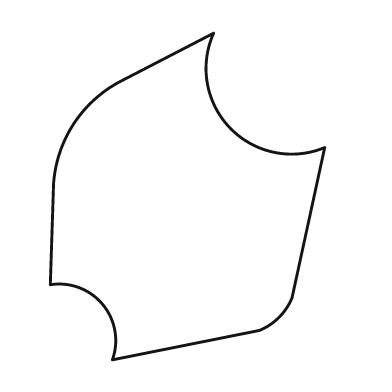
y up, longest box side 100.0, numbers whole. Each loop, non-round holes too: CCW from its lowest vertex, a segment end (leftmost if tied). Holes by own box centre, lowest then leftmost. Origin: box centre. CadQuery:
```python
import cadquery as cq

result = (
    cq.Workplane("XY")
    .moveTo(-23.0, -50.0)
    .lineTo(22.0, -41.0)
    .threePointArc((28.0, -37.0), (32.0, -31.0))
    .lineTo(42.0, 15.0)
    .threePointArc((13.0, 21.0), (8.0, 50.0))
    .lineTo(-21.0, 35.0)
    .threePointArc((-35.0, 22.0), (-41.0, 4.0))
    .lineTo(-42.0, -27.0)
    .threePointArc((-26.0, -33.0), (-23.0, -50.0))
    .close()
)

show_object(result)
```